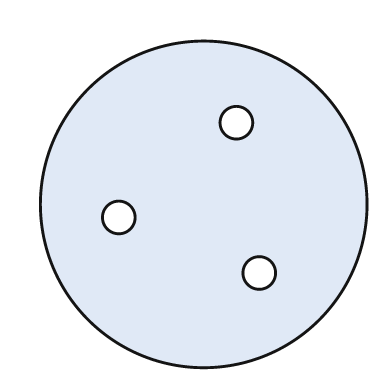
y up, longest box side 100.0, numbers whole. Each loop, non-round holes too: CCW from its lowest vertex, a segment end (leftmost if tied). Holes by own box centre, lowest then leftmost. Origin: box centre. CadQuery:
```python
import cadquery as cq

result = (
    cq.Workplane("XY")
    .moveTo(0.0, 0.0)
    .circle(50.0)
    .moveTo(17.0, -21.0)
    .circle(5.0)
    .moveTo(-26.0, -4.0)
    .circle(5.0)
    .moveTo(10.0, 25.0)
    .circle(5.0)
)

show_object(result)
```